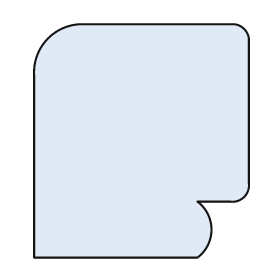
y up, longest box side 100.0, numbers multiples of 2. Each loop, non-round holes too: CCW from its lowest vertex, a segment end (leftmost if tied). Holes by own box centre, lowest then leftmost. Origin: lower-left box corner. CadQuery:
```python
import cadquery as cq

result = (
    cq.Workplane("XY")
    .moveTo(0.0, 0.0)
    .lineTo(70.0, 0.0)
    .threePointArc((76.0, 12.0), (70.0, 24.0))
    .lineTo(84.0, 24.0)
    .threePointArc((90.0, 26.0), (92.0, 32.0))
    .lineTo(92.0, 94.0)
    .threePointArc((90.0, 98.0), (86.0, 100.0))
    .lineTo(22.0, 100.0)
    .threePointArc((6.0, 94.0), (0.0, 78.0))
    .close()
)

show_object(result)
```